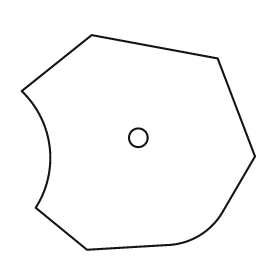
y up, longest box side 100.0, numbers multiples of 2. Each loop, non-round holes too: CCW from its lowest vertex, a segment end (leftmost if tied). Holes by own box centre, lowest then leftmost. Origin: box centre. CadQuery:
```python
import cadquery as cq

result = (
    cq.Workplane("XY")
    .moveTo(-22.0, -46.0)
    .lineTo(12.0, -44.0)
    .threePointArc((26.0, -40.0), (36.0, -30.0))
    .lineTo(50.0, -6.0)
    .lineTo(34.0, 36.0)
    .lineTo(-20.0, 46.0)
    .lineTo(-50.0, 22.0)
    .threePointArc((-38.0, -2.0), (-44.0, -28.0))
    .close()
    .moveTo(0.0, 2.0)
    .circle(4.0)
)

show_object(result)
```